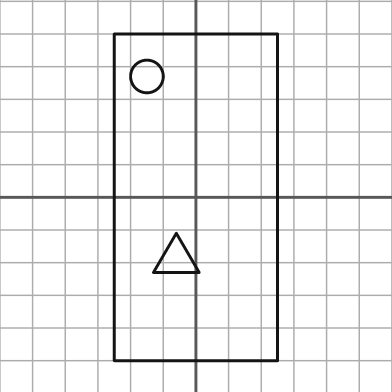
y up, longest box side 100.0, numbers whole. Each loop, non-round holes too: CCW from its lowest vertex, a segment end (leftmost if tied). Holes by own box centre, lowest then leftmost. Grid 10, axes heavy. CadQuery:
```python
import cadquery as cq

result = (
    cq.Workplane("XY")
    .moveTo(-25.0, -50.0)
    .lineTo(25.0, -50.0)
    .lineTo(25.0, 50.0)
    .lineTo(-25.0, 50.0)
    .close()
    .moveTo(-13.0, -23.0)
    .lineTo(1.0, -23.0)
    .lineTo(-6.0, -11.0)
    .close()
    .moveTo(-15.0, 37.0)
    .circle(5.0)
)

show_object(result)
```